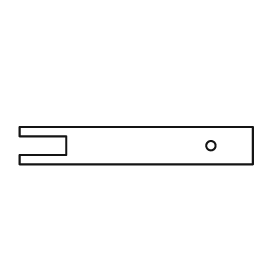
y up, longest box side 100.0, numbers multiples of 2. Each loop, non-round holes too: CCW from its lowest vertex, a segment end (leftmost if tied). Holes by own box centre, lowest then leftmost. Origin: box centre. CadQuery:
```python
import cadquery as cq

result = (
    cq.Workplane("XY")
    .moveTo(-50.0, -8.0)
    .lineTo(50.0, -8.0)
    .lineTo(50.0, 8.0)
    .lineTo(-50.0, 8.0)
    .lineTo(-50.0, 4.0)
    .lineTo(-30.0, 4.0)
    .lineTo(-30.0, -4.0)
    .lineTo(-50.0, -4.0)
    .close()
    .moveTo(32.0, 0.0)
    .circle(2.0)
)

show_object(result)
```